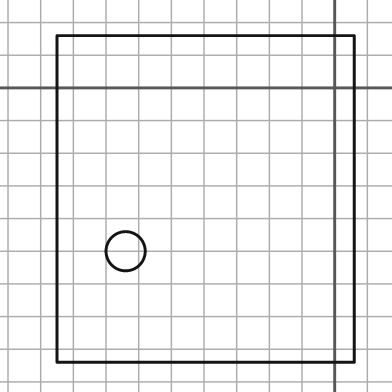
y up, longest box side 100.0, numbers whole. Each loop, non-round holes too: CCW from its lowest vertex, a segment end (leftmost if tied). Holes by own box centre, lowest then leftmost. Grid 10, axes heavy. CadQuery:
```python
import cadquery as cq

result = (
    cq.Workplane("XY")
    .moveTo(-85.0, -84.0)
    .lineTo(6.0, -84.0)
    .lineTo(6.0, 16.0)
    .lineTo(-85.0, 16.0)
    .close()
    .moveTo(-64.0, -50.0)
    .circle(6.0)
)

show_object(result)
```